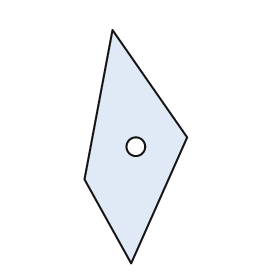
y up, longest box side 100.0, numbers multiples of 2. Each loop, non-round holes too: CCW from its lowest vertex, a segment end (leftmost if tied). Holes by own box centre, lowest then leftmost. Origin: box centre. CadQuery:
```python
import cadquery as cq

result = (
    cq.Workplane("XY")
    .moveTo(-2.0, -50.0)
    .lineTo(22.0, 4.0)
    .lineTo(-10.0, 50.0)
    .lineTo(-22.0, -14.0)
    .close()
    .moveTo(0.0, 0.0)
    .circle(4.0)
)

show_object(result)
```